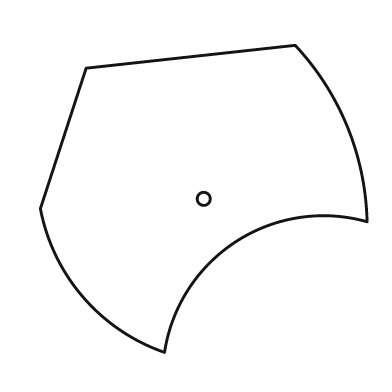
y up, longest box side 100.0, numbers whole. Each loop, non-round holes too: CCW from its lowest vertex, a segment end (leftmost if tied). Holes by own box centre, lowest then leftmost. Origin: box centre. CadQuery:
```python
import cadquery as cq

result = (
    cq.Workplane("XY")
    .moveTo(-12.0, -47.0)
    .threePointArc((10.0, -13.0), (50.0, -7.0))
    .threePointArc((44.0, 22.0), (28.0, 47.0))
    .lineTo(-36.0, 40.0)
    .lineTo(-50.0, -3.0)
    .threePointArc((-37.0, -30.0), (-12.0, -47.0))
    .close()
    .moveTo(0.0, 0.0)
    .circle(2.0)
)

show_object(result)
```